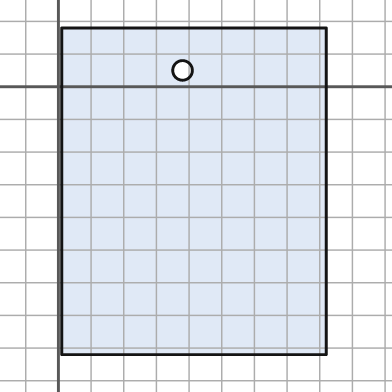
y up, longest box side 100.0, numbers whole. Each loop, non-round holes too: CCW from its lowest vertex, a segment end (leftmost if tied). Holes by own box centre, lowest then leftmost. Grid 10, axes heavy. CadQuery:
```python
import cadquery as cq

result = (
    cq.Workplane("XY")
    .moveTo(1.0, -82.0)
    .lineTo(82.0, -82.0)
    .lineTo(82.0, 18.0)
    .lineTo(1.0, 18.0)
    .close()
    .moveTo(38.0, 5.0)
    .circle(3.0)
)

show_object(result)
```